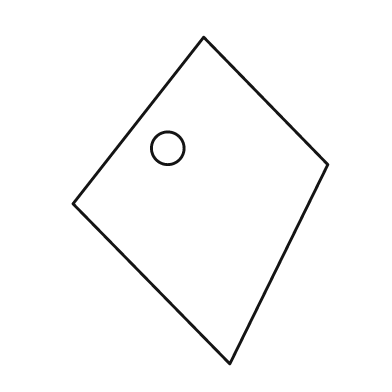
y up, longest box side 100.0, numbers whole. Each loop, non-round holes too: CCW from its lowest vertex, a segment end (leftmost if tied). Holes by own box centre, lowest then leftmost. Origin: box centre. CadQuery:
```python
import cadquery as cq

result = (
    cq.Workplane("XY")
    .moveTo(9.0, -50.0)
    .lineTo(39.0, 11.0)
    .lineTo(1.0, 50.0)
    .lineTo(-39.0, -1.0)
    .close()
    .moveTo(-10.0, 16.0)
    .circle(5.0)
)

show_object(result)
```